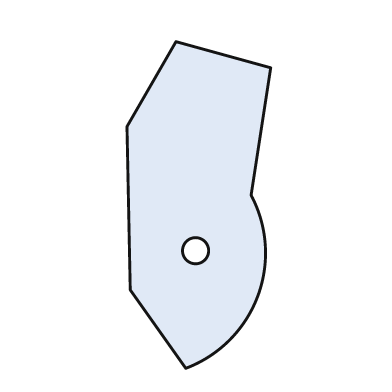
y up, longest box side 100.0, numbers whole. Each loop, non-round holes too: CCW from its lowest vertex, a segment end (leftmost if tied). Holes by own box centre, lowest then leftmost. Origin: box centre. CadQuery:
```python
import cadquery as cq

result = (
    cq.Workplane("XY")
    .moveTo(-4.0, -50.0)
    .threePointArc((18.0, -28.0), (16.0, 3.0))
    .lineTo(22.0, 42.0)
    .lineTo(-7.0, 50.0)
    .lineTo(-22.0, 24.0)
    .lineTo(-21.0, -26.0)
    .close()
    .moveTo(-1.0, -14.0)
    .circle(4.0)
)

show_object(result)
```